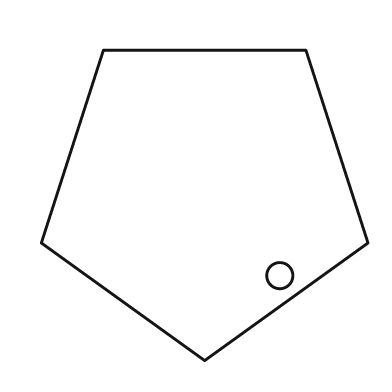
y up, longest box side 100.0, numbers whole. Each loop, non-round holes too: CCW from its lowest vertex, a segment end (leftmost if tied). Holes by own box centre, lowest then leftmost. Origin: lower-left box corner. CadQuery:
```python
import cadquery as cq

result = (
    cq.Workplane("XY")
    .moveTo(50.0, 0.0)
    .lineTo(100.0, 36.0)
    .lineTo(81.0, 95.0)
    .lineTo(19.0, 95.0)
    .lineTo(0.0, 36.0)
    .close()
    .moveTo(73.0, 26.0)
    .circle(4.0)
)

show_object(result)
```